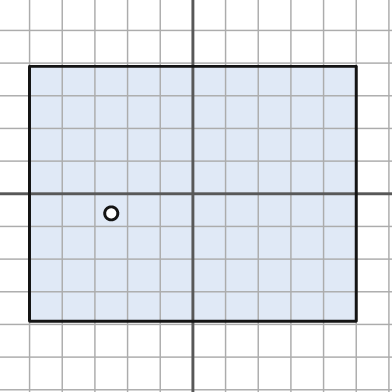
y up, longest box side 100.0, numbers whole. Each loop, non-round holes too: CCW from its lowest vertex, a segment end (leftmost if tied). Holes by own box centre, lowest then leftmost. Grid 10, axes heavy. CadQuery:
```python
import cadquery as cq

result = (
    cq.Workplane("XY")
    .moveTo(-50.0, -39.0)
    .lineTo(50.0, -39.0)
    .lineTo(50.0, 39.0)
    .lineTo(-50.0, 39.0)
    .close()
    .moveTo(-25.0, -6.0)
    .circle(2.0)
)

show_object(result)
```